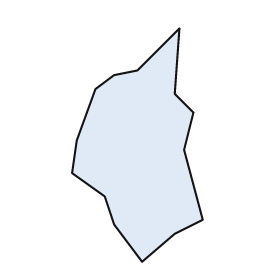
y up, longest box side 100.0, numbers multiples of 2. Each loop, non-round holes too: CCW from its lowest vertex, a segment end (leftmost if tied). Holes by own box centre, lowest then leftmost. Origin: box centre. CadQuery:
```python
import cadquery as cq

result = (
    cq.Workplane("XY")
    .moveTo(2.0, -50.0)
    .lineTo(16.0, -38.0)
    .lineTo(28.0, -32.0)
    .lineTo(20.0, -2.0)
    .lineTo(24.0, 14.0)
    .lineTo(16.0, 22.0)
    .lineTo(18.0, 50.0)
    .lineTo(0.0, 32.0)
    .lineTo(-10.0, 30.0)
    .lineTo(-18.0, 24.0)
    .lineTo(-26.0, 2.0)
    .lineTo(-28.0, -12.0)
    .lineTo(-14.0, -22.0)
    .lineTo(-10.0, -34.0)
    .close()
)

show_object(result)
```